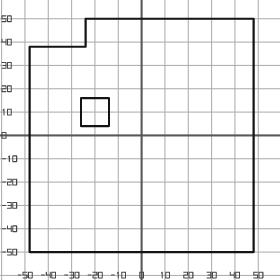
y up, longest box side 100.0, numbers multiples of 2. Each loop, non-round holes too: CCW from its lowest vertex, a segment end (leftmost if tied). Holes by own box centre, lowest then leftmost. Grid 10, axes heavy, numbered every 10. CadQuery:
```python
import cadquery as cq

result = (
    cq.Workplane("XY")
    .moveTo(-48.0, -50.0)
    .lineTo(48.0, -50.0)
    .lineTo(48.0, 50.0)
    .lineTo(-24.0, 50.0)
    .lineTo(-24.0, 38.0)
    .lineTo(-48.0, 38.0)
    .close()
    .moveTo(-26.0, 4.0)
    .lineTo(-14.0, 4.0)
    .lineTo(-14.0, 16.0)
    .lineTo(-26.0, 16.0)
    .close()
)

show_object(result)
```